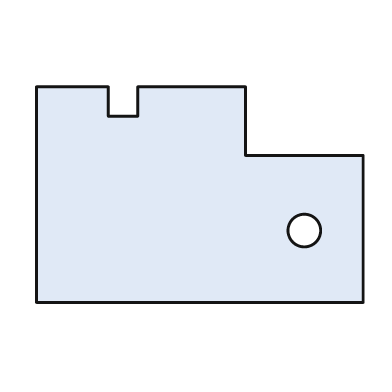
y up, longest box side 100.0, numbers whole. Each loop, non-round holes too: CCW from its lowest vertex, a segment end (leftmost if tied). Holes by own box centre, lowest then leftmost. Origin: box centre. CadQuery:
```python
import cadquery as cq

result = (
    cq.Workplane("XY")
    .moveTo(-50.0, -33.0)
    .lineTo(50.0, -33.0)
    .lineTo(50.0, 12.0)
    .lineTo(14.0, 12.0)
    .lineTo(14.0, 33.0)
    .lineTo(-19.0, 33.0)
    .lineTo(-19.0, 24.0)
    .lineTo(-28.0, 24.0)
    .lineTo(-28.0, 33.0)
    .lineTo(-50.0, 33.0)
    .close()
    .moveTo(32.0, -11.0)
    .circle(5.0)
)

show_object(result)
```